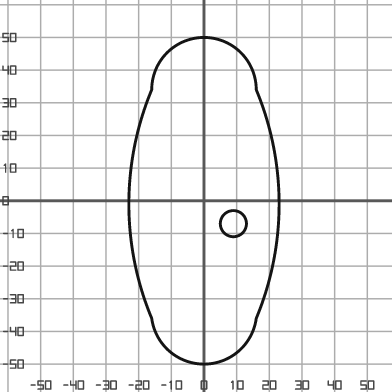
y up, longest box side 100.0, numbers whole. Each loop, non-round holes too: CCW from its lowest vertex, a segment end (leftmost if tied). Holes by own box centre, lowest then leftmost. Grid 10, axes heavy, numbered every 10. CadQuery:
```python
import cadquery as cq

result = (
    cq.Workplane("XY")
    .moveTo(-16.0, -36.0)
    .threePointArc((0.0, -50.0), (16.0, -36.0))
    .threePointArc((23.0, -1.0), (16.0, 34.0))
    .threePointArc((0.0, 50.0), (-16.0, 34.0))
    .threePointArc((-23.0, -1.0), (-16.0, -36.0))
    .close()
    .moveTo(9.0, -7.0)
    .circle(4.0)
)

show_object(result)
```